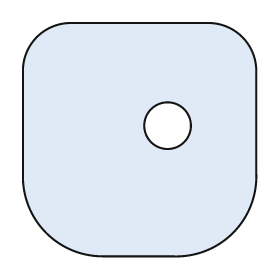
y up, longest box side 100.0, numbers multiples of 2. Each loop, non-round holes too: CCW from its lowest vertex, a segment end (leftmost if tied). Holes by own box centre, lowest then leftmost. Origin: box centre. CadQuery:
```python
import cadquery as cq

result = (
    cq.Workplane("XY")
    .moveTo(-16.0, -50.0)
    .lineTo(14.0, -50.0)
    .threePointArc((40.0, -40.0), (50.0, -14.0))
    .lineTo(50.0, 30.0)
    .threePointArc((44.0, 44.0), (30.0, 50.0))
    .lineTo(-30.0, 50.0)
    .threePointArc((-44.0, 44.0), (-50.0, 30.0))
    .lineTo(-50.0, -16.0)
    .threePointArc((-40.0, -40.0), (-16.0, -50.0))
    .close()
    .moveTo(12.0, 6.0)
    .circle(10.0)
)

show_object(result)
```